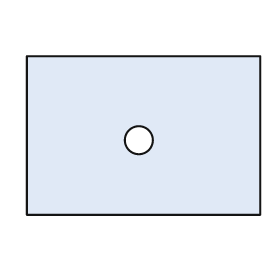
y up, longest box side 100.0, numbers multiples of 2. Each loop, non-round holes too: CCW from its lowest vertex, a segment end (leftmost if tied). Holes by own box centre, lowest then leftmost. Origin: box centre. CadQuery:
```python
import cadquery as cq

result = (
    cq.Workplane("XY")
    .moveTo(-50.0, -34.0)
    .lineTo(50.0, -34.0)
    .lineTo(50.0, 34.0)
    .lineTo(-50.0, 34.0)
    .close()
    .moveTo(-2.0, -2.0)
    .circle(6.0)
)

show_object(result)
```